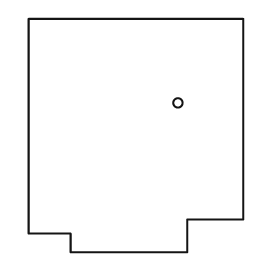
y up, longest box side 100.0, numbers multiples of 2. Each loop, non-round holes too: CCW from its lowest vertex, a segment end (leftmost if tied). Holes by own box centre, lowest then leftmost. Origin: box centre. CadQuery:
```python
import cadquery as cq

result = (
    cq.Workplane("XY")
    .moveTo(-28.0, -50.0)
    .lineTo(22.0, -50.0)
    .lineTo(22.0, -36.0)
    .lineTo(46.0, -36.0)
    .lineTo(46.0, 50.0)
    .lineTo(-46.0, 50.0)
    .lineTo(-46.0, -42.0)
    .lineTo(-28.0, -42.0)
    .close()
    .moveTo(18.0, 14.0)
    .circle(2.0)
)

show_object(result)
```